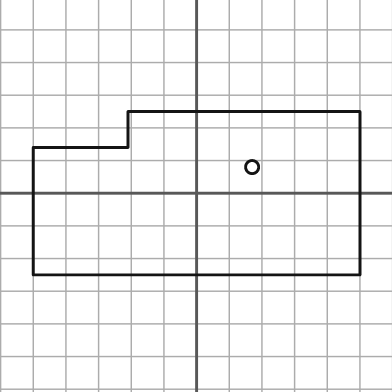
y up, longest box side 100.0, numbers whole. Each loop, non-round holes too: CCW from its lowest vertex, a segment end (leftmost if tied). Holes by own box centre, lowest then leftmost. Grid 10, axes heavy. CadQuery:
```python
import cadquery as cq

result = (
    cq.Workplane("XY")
    .moveTo(-50.0, -25.0)
    .lineTo(50.0, -25.0)
    .lineTo(50.0, 25.0)
    .lineTo(-21.0, 25.0)
    .lineTo(-21.0, 14.0)
    .lineTo(-50.0, 14.0)
    .close()
    .moveTo(17.0, 8.0)
    .circle(2.0)
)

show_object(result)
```